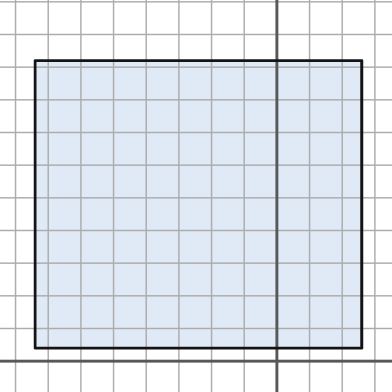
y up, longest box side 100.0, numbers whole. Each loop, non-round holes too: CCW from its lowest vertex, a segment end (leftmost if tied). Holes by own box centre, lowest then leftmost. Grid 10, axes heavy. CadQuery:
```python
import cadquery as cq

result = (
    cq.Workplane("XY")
    .moveTo(-74.0, 4.0)
    .lineTo(26.0, 4.0)
    .lineTo(26.0, 92.0)
    .lineTo(-74.0, 92.0)
    .close()
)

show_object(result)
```